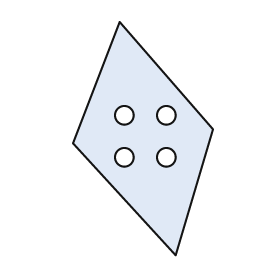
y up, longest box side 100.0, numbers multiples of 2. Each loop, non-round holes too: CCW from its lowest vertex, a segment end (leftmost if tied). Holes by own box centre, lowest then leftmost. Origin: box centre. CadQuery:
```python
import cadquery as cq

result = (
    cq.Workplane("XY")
    .moveTo(14.0, -50.0)
    .lineTo(30.0, 4.0)
    .lineTo(-10.0, 50.0)
    .lineTo(-30.0, -2.0)
    .close()
    .moveTo(-8.0, -8.0)
    .circle(4.0)
    .moveTo(10.0, -8.0)
    .circle(4.0)
    .moveTo(-8.0, 10.0)
    .circle(4.0)
    .moveTo(10.0, 10.0)
    .circle(4.0)
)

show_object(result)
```